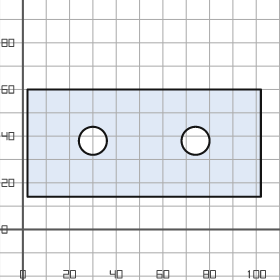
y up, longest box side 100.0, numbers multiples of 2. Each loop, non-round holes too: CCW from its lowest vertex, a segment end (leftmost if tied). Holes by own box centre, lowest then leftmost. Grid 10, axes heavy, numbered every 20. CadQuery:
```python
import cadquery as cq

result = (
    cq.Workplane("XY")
    .moveTo(2.0, 14.0)
    .lineTo(102.0, 14.0)
    .lineTo(102.0, 60.0)
    .lineTo(2.0, 60.0)
    .close()
    .moveTo(30.0, 38.0)
    .circle(6.0)
    .moveTo(74.0, 38.0)
    .circle(6.0)
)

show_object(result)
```